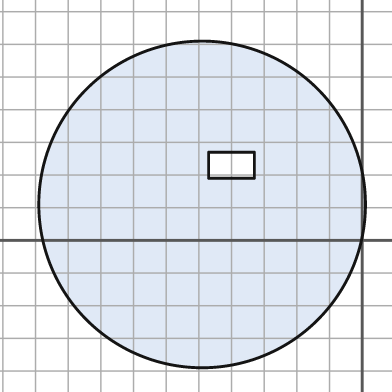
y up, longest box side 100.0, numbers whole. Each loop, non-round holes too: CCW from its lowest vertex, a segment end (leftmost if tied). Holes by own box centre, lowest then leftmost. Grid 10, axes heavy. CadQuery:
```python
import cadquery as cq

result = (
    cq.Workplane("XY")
    .moveTo(-49.0, 11.0)
    .circle(50.0)
    .moveTo(-47.0, 19.0)
    .lineTo(-33.0, 19.0)
    .lineTo(-33.0, 27.0)
    .lineTo(-47.0, 27.0)
    .close()
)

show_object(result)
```